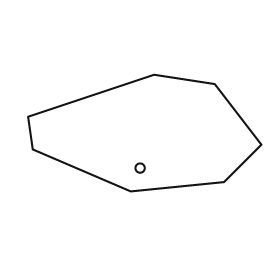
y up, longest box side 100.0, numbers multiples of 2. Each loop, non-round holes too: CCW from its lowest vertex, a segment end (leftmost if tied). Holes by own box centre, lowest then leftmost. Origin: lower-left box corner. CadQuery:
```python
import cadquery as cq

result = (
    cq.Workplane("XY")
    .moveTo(44.0, 0.0)
    .lineTo(84.0, 4.0)
    .lineTo(100.0, 20.0)
    .lineTo(80.0, 46.0)
    .lineTo(54.0, 50.0)
    .lineTo(0.0, 32.0)
    .lineTo(2.0, 18.0)
    .close()
    .moveTo(48.0, 10.0)
    .circle(2.0)
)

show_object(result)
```